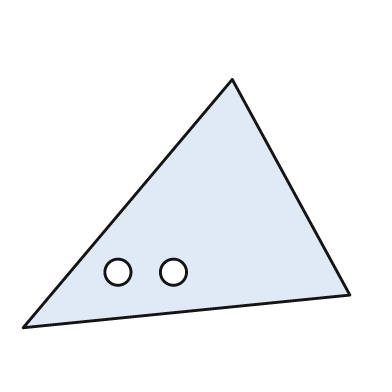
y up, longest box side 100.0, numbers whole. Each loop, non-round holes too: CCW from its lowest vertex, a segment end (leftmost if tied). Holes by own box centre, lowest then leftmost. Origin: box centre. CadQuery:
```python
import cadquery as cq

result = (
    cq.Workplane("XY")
    .moveTo(-50.0, -38.0)
    .lineTo(50.0, -28.0)
    .lineTo(14.0, 38.0)
    .close()
    .moveTo(-21.0, -21.0)
    .circle(4.0)
    .moveTo(-4.0, -21.0)
    .circle(4.0)
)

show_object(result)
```